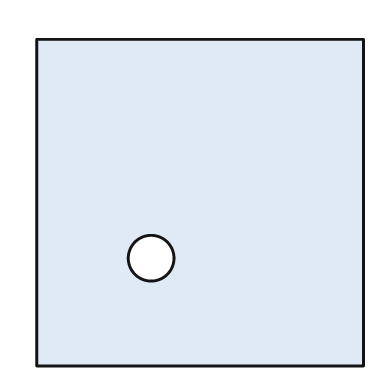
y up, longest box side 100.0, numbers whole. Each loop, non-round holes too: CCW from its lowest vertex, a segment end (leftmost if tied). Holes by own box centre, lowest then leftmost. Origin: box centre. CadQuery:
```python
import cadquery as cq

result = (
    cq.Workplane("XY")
    .moveTo(-50.0, -50.0)
    .lineTo(50.0, -50.0)
    .lineTo(50.0, 50.0)
    .lineTo(-50.0, 50.0)
    .close()
    .moveTo(-15.0, -17.0)
    .circle(7.0)
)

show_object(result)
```